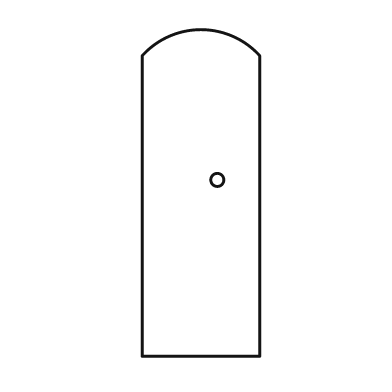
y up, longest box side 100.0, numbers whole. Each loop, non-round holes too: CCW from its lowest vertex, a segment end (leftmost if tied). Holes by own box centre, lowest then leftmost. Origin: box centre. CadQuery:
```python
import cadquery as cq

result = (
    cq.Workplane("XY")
    .moveTo(-18.0, -50.0)
    .lineTo(18.0, -50.0)
    .lineTo(18.0, 42.0)
    .threePointArc((0.0, 50.0), (-18.0, 42.0))
    .close()
    .moveTo(5.0, 4.0)
    .circle(2.0)
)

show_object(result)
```